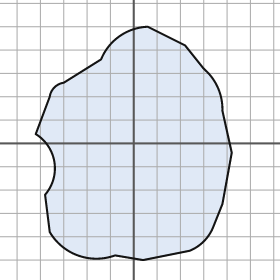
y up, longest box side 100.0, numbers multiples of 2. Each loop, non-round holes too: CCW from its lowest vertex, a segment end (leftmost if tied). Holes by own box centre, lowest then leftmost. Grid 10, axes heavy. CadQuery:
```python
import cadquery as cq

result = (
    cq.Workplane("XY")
    .moveTo(4.0, -50.0)
    .lineTo(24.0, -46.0)
    .threePointArc((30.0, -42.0), (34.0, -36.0))
    .lineTo(38.0, -26.0)
    .lineTo(42.0, -4.0)
    .lineTo(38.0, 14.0)
    .threePointArc((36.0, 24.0), (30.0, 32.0))
    .lineTo(22.0, 42.0)
    .lineTo(6.0, 50.0)
    .threePointArc((-6.0, 46.0), (-14.0, 36.0))
    .lineTo(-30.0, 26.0)
    .threePointArc((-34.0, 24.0), (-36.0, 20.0))
    .lineTo(-42.0, 4.0)
    .threePointArc((-34.0, -8.0), (-38.0, -22.0))
    .lineTo(-36.0, -38.0)
    .threePointArc((-24.0, -48.0), (-8.0, -48.0))
    .close()
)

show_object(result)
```